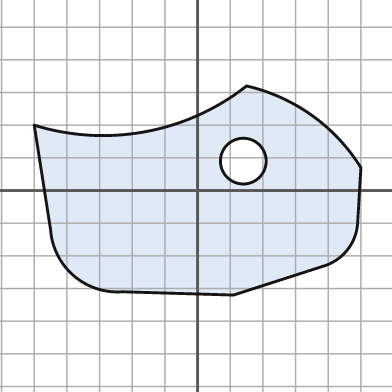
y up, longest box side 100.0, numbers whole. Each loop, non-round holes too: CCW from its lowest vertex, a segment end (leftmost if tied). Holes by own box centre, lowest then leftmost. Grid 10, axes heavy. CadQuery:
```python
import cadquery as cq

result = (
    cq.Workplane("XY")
    .moveTo(11.0, -32.0)
    .lineTo(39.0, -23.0)
    .threePointArc((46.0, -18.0), (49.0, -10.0))
    .lineTo(50.0, 7.0)
    .threePointArc((35.0, 23.0), (15.0, 32.0))
    .threePointArc((-16.0, 18.0), (-50.0, 20.0))
    .lineTo(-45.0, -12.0)
    .threePointArc((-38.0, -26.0), (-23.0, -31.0))
    .close()
    .moveTo(14.0, 9.0)
    .circle(7.0)
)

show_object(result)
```